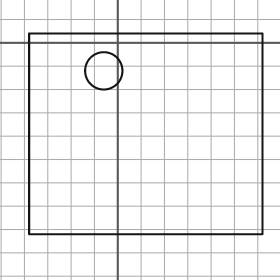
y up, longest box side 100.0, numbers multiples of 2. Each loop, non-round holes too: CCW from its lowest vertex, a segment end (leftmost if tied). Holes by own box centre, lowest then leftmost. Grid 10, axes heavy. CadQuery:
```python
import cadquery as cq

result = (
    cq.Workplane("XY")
    .moveTo(-38.0, -82.0)
    .lineTo(62.0, -82.0)
    .lineTo(62.0, 4.0)
    .lineTo(-38.0, 4.0)
    .close()
    .moveTo(-6.0, -12.0)
    .circle(8.0)
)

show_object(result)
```